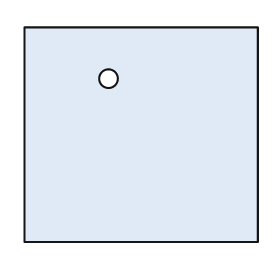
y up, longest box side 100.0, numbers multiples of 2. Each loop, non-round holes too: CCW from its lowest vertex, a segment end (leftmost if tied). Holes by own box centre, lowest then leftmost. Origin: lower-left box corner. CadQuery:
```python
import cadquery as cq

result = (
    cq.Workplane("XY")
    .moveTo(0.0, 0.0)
    .lineTo(100.0, 0.0)
    .lineTo(100.0, 92.0)
    .lineTo(0.0, 92.0)
    .close()
    .moveTo(36.0, 70.0)
    .circle(4.0)
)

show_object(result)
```